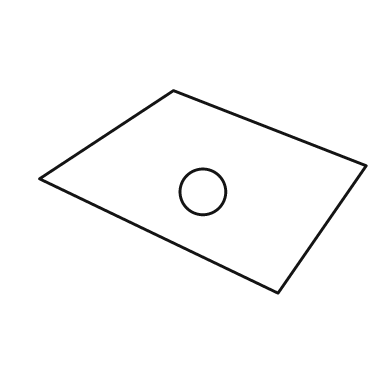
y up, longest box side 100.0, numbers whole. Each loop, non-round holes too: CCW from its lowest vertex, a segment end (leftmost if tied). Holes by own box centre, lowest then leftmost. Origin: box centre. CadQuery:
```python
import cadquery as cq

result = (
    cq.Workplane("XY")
    .moveTo(23.0, -31.0)
    .lineTo(50.0, 8.0)
    .lineTo(-9.0, 31.0)
    .lineTo(-50.0, 4.0)
    .close()
    .moveTo(0.0, 0.0)
    .circle(7.0)
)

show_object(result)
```